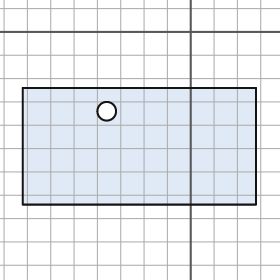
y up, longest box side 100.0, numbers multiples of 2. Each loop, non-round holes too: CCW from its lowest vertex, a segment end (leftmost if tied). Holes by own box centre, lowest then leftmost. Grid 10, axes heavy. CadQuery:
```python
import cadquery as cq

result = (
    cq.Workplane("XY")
    .moveTo(-72.0, -74.0)
    .lineTo(28.0, -74.0)
    .lineTo(28.0, -24.0)
    .lineTo(-72.0, -24.0)
    .close()
    .moveTo(-36.0, -34.0)
    .circle(4.0)
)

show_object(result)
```